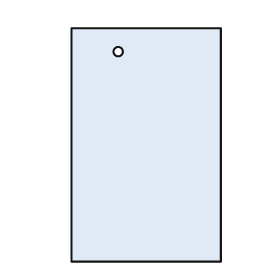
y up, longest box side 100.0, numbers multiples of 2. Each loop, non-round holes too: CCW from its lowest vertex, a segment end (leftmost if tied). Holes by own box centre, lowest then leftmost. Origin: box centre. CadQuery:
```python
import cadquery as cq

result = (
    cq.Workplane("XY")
    .moveTo(-32.0, -50.0)
    .lineTo(32.0, -50.0)
    .lineTo(32.0, 50.0)
    .lineTo(-32.0, 50.0)
    .close()
    .moveTo(-12.0, 40.0)
    .circle(2.0)
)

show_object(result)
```